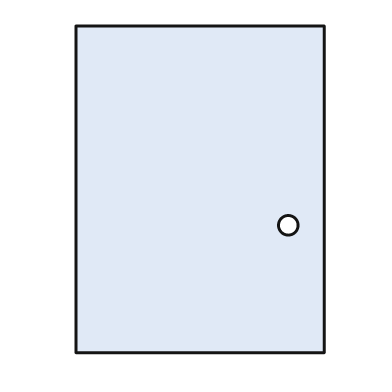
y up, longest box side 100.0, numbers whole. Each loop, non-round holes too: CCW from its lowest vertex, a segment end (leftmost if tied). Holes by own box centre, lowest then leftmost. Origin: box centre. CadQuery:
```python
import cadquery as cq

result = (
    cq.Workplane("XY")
    .moveTo(-38.0, -50.0)
    .lineTo(38.0, -50.0)
    .lineTo(38.0, 50.0)
    .lineTo(-38.0, 50.0)
    .close()
    .moveTo(27.0, -11.0)
    .circle(3.0)
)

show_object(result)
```